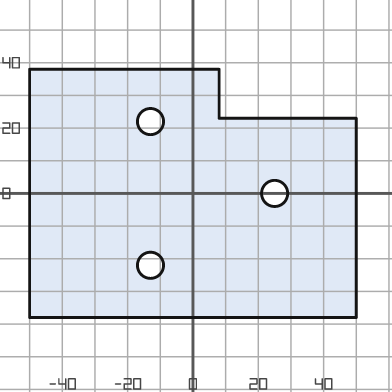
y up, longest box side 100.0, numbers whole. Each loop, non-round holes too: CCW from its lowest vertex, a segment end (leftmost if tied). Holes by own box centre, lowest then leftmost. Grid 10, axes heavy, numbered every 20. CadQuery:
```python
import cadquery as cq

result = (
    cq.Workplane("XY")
    .moveTo(-50.0, -38.0)
    .lineTo(50.0, -38.0)
    .lineTo(50.0, 23.0)
    .lineTo(8.0, 23.0)
    .lineTo(8.0, 38.0)
    .lineTo(-50.0, 38.0)
    .close()
    .moveTo(-13.0, -22.0)
    .circle(4.0)
    .moveTo(25.0, 0.0)
    .circle(4.0)
    .moveTo(-13.0, 22.0)
    .circle(4.0)
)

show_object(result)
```